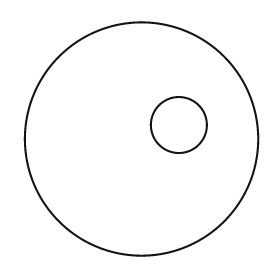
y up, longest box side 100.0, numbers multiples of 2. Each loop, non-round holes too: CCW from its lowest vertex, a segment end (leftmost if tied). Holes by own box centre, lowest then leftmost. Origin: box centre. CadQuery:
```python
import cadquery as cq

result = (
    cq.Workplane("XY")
    .moveTo(0.0, 0.0)
    .circle(50.0)
    .moveTo(16.0, 6.0)
    .circle(12.0)
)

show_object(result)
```